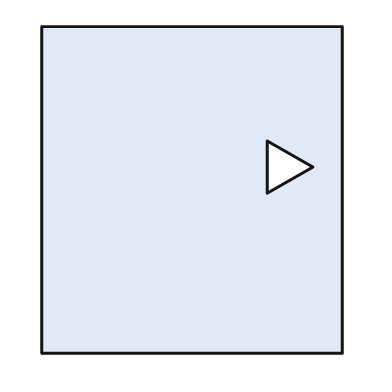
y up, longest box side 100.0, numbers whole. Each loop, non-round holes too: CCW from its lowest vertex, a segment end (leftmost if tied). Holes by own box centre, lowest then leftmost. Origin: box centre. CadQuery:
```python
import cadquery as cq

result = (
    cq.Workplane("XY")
    .moveTo(-46.0, -50.0)
    .lineTo(46.0, -50.0)
    .lineTo(46.0, 50.0)
    .lineTo(-46.0, 50.0)
    .close()
    .moveTo(23.0, -1.0)
    .lineTo(37.0, 7.0)
    .lineTo(23.0, 15.0)
    .close()
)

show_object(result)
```